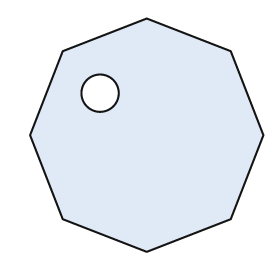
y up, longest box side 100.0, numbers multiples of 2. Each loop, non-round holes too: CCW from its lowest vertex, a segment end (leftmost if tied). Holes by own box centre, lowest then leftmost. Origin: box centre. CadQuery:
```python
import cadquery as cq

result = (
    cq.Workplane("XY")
    .moveTo(0.0, -50.0)
    .lineTo(36.0, -36.0)
    .lineTo(50.0, 0.0)
    .lineTo(36.0, 36.0)
    .lineTo(0.0, 50.0)
    .lineTo(-36.0, 36.0)
    .lineTo(-50.0, 0.0)
    .lineTo(-36.0, -36.0)
    .close()
    .moveTo(-20.0, 18.0)
    .circle(8.0)
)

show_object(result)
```